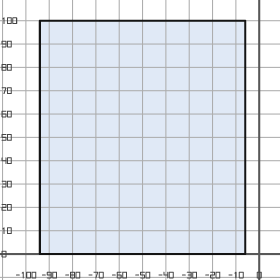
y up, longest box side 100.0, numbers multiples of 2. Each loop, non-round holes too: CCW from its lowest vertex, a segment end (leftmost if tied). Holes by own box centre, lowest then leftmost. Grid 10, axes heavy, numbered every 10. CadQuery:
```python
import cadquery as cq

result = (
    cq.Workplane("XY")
    .moveTo(-94.0, 0.0)
    .lineTo(-6.0, 0.0)
    .lineTo(-6.0, 100.0)
    .lineTo(-94.0, 100.0)
    .close()
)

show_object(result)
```